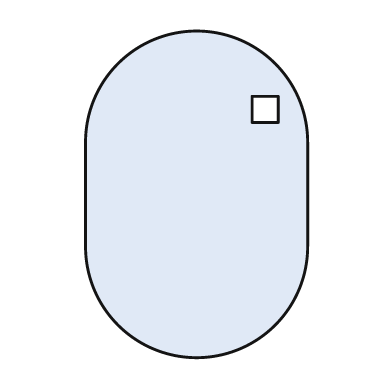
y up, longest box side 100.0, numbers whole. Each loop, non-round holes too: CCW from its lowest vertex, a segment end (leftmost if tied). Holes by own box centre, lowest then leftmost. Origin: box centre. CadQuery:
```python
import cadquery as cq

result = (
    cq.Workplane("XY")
    .moveTo(-34.0, -16.0)
    .threePointArc((0.0, -50.0), (34.0, -16.0))
    .lineTo(34.0, 16.0)
    .threePointArc((0.0, 50.0), (-34.0, 16.0))
    .close()
    .moveTo(17.0, 22.0)
    .lineTo(25.0, 22.0)
    .lineTo(25.0, 30.0)
    .lineTo(17.0, 30.0)
    .close()
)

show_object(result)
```